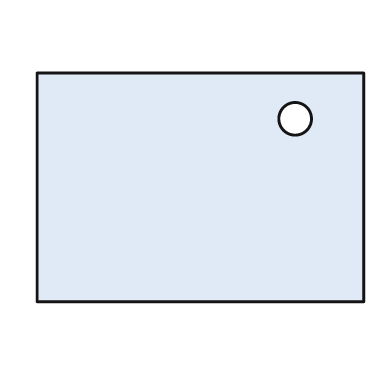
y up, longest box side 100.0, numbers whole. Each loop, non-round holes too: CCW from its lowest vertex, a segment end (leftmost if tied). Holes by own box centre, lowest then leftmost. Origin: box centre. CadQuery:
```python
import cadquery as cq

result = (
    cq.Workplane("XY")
    .moveTo(-50.0, -35.0)
    .lineTo(50.0, -35.0)
    .lineTo(50.0, 35.0)
    .lineTo(-50.0, 35.0)
    .close()
    .moveTo(29.0, 21.0)
    .circle(5.0)
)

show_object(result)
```